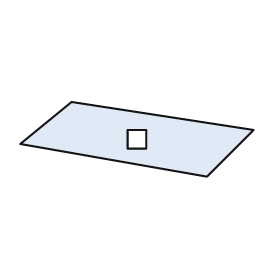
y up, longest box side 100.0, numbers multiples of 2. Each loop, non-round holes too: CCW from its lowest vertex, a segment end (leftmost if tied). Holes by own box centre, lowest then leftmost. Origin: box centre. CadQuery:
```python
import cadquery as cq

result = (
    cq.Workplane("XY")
    .moveTo(30.0, -16.0)
    .lineTo(50.0, 4.0)
    .lineTo(-28.0, 16.0)
    .lineTo(-50.0, -2.0)
    .close()
    .moveTo(-4.0, -4.0)
    .lineTo(4.0, -4.0)
    .lineTo(4.0, 4.0)
    .lineTo(-4.0, 4.0)
    .close()
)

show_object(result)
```